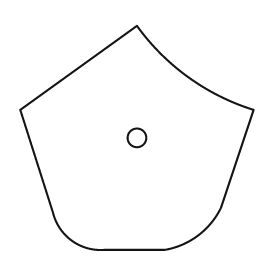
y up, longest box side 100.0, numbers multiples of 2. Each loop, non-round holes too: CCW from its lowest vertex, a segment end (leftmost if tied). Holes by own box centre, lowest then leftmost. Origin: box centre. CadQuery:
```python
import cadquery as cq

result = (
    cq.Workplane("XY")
    .moveTo(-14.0, -48.0)
    .lineTo(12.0, -48.0)
    .threePointArc((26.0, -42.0), (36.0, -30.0))
    .lineTo(50.0, 12.0)
    .threePointArc((22.0, 26.0), (0.0, 48.0))
    .lineTo(-50.0, 12.0)
    .lineTo(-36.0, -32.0)
    .threePointArc((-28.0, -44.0), (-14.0, -48.0))
    .close()
    .moveTo(0.0, 0.0)
    .circle(4.0)
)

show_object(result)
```